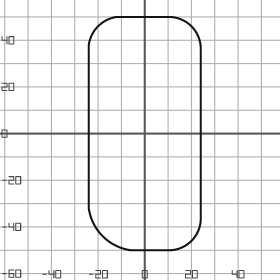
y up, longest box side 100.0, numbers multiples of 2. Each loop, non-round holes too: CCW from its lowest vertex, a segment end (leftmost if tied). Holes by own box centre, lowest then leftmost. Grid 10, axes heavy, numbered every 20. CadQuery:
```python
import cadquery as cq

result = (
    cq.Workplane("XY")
    .moveTo(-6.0, -50.0)
    .lineTo(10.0, -50.0)
    .threePointArc((20.0, -46.0), (24.0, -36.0))
    .lineTo(24.0, 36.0)
    .threePointArc((20.0, 46.0), (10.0, 50.0))
    .lineTo(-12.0, 50.0)
    .threePointArc((-20.0, 46.0), (-24.0, 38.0))
    .lineTo(-24.0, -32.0)
    .threePointArc((-18.0, -44.0), (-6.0, -50.0))
    .close()
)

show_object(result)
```